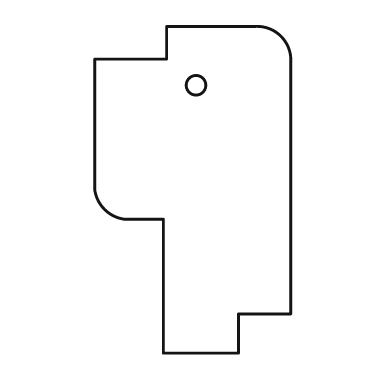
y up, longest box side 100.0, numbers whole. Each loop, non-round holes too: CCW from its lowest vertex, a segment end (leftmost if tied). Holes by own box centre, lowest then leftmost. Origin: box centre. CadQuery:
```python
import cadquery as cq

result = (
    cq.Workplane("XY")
    .moveTo(-9.0, -50.0)
    .lineTo(14.0, -50.0)
    .lineTo(14.0, -38.0)
    .lineTo(30.0, -38.0)
    .lineTo(30.0, 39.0)
    .threePointArc((27.0, 47.0), (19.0, 50.0))
    .lineTo(-8.0, 50.0)
    .lineTo(-8.0, 40.0)
    .lineTo(-30.0, 40.0)
    .lineTo(-30.0, 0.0)
    .threePointArc((-27.0, -6.0), (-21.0, -9.0))
    .lineTo(-9.0, -9.0)
    .close()
    .moveTo(1.0, 32.0)
    .circle(3.0)
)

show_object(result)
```